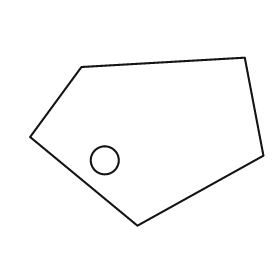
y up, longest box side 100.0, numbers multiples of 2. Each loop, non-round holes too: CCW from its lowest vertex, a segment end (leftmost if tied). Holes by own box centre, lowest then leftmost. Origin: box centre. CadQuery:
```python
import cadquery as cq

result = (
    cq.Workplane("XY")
    .moveTo(-4.0, -36.0)
    .lineTo(50.0, -6.0)
    .lineTo(42.0, 36.0)
    .lineTo(-28.0, 32.0)
    .lineTo(-50.0, 2.0)
    .close()
    .moveTo(-18.0, -8.0)
    .circle(6.0)
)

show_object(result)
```